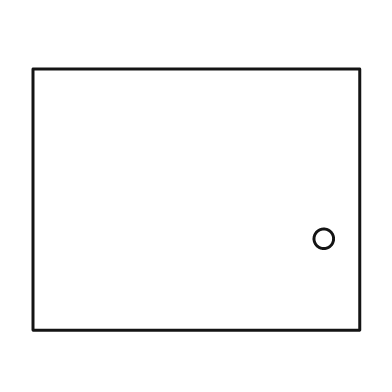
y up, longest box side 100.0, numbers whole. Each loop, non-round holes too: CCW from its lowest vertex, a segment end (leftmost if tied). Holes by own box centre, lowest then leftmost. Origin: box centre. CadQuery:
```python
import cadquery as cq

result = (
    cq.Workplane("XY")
    .moveTo(-50.0, -40.0)
    .lineTo(50.0, -40.0)
    .lineTo(50.0, 40.0)
    .lineTo(-50.0, 40.0)
    .close()
    .moveTo(39.0, -12.0)
    .circle(3.0)
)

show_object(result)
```